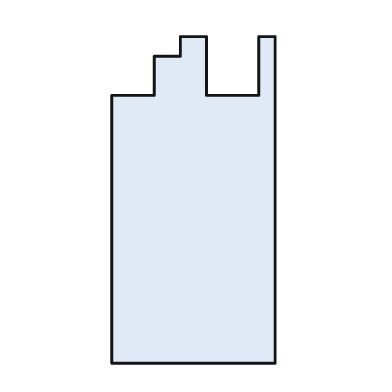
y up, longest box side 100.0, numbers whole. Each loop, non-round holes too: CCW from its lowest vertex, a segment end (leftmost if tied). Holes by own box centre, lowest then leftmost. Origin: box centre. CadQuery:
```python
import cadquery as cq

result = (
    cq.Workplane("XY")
    .moveTo(-25.0, -50.0)
    .lineTo(25.0, -50.0)
    .lineTo(25.0, 50.0)
    .lineTo(20.0, 50.0)
    .lineTo(20.0, 32.0)
    .lineTo(4.0, 32.0)
    .lineTo(4.0, 50.0)
    .lineTo(-4.0, 50.0)
    .lineTo(-4.0, 44.0)
    .lineTo(-12.0, 44.0)
    .lineTo(-12.0, 32.0)
    .lineTo(-25.0, 32.0)
    .close()
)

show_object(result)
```